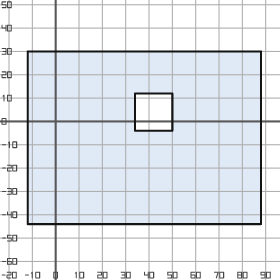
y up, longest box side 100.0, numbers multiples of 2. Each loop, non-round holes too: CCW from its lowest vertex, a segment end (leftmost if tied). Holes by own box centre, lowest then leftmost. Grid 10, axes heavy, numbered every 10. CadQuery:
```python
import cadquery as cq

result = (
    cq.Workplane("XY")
    .moveTo(-12.0, -44.0)
    .lineTo(88.0, -44.0)
    .lineTo(88.0, 30.0)
    .lineTo(-12.0, 30.0)
    .close()
    .moveTo(34.0, -4.0)
    .lineTo(50.0, -4.0)
    .lineTo(50.0, 12.0)
    .lineTo(34.0, 12.0)
    .close()
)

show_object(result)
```